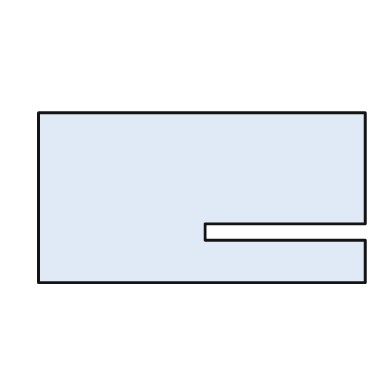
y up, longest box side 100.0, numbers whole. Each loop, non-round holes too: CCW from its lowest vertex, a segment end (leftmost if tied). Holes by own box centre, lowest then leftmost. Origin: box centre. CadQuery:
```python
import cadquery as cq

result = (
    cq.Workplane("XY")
    .moveTo(-50.0, -26.0)
    .lineTo(50.0, -26.0)
    .lineTo(50.0, -13.0)
    .lineTo(1.0, -13.0)
    .lineTo(1.0, -8.0)
    .lineTo(50.0, -8.0)
    .lineTo(50.0, 26.0)
    .lineTo(-50.0, 26.0)
    .close()
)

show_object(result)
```